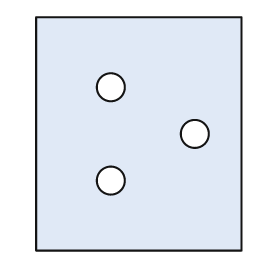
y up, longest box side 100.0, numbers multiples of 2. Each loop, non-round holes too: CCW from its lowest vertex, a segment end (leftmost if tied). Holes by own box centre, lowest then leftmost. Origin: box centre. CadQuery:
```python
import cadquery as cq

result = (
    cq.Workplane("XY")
    .moveTo(-44.0, -50.0)
    .lineTo(44.0, -50.0)
    .lineTo(44.0, 50.0)
    .lineTo(-44.0, 50.0)
    .close()
    .moveTo(-12.0, -20.0)
    .circle(6.0)
    .moveTo(24.0, 0.0)
    .circle(6.0)
    .moveTo(-12.0, 20.0)
    .circle(6.0)
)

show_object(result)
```